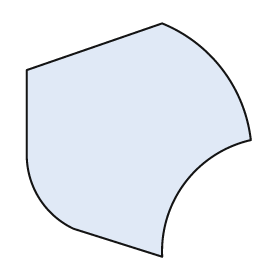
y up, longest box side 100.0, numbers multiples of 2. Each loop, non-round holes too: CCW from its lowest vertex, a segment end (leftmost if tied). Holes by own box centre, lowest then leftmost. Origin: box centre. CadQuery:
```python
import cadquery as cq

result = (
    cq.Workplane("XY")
    .moveTo(10.0, -50.0)
    .threePointArc((20.0, -18.0), (48.0, 0.0))
    .threePointArc((36.0, 30.0), (10.0, 50.0))
    .lineTo(-48.0, 30.0)
    .lineTo(-48.0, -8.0)
    .threePointArc((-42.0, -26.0), (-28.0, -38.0))
    .close()
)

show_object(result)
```